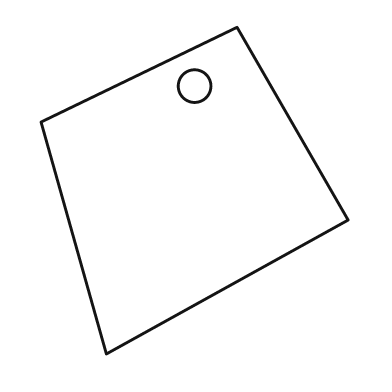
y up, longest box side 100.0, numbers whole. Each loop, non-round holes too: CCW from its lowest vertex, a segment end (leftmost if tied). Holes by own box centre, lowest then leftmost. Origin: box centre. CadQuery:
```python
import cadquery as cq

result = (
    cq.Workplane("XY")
    .moveTo(-27.0, -50.0)
    .lineTo(47.0, -9.0)
    .lineTo(13.0, 50.0)
    .lineTo(-47.0, 21.0)
    .close()
    .moveTo(0.0, 32.0)
    .circle(5.0)
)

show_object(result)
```